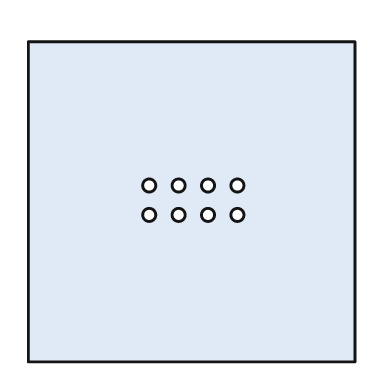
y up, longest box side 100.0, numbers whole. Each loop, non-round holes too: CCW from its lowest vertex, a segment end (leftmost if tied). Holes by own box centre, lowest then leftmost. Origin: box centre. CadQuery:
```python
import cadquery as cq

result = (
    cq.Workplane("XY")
    .moveTo(-50.0, -49.0)
    .lineTo(50.0, -49.0)
    .lineTo(50.0, 49.0)
    .lineTo(-50.0, 49.0)
    .close()
    .moveTo(-13.0, -4.0)
    .circle(2.0)
    .moveTo(-4.0, -4.0)
    .circle(2.0)
    .moveTo(5.0, -4.0)
    .circle(2.0)
    .moveTo(14.0, -4.0)
    .circle(2.0)
    .moveTo(-13.0, 5.0)
    .circle(2.0)
    .moveTo(-4.0, 5.0)
    .circle(2.0)
    .moveTo(5.0, 5.0)
    .circle(2.0)
    .moveTo(14.0, 5.0)
    .circle(2.0)
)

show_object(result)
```